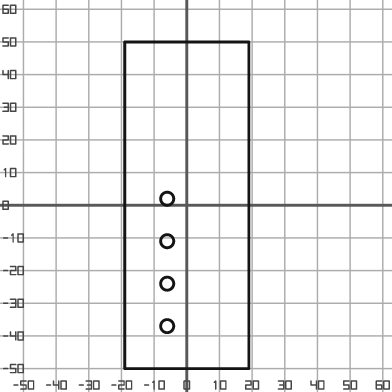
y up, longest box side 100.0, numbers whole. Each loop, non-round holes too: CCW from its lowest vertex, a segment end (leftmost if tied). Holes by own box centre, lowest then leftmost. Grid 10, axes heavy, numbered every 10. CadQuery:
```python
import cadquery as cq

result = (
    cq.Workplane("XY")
    .moveTo(-19.0, -50.0)
    .lineTo(19.0, -50.0)
    .lineTo(19.0, 50.0)
    .lineTo(-19.0, 50.0)
    .close()
    .moveTo(-6.0, -37.0)
    .circle(2.0)
    .moveTo(-6.0, -24.0)
    .circle(2.0)
    .moveTo(-6.0, -11.0)
    .circle(2.0)
    .moveTo(-6.0, 2.0)
    .circle(2.0)
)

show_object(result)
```